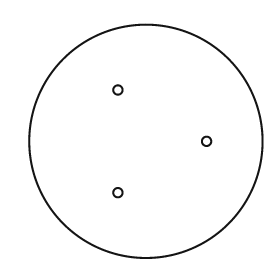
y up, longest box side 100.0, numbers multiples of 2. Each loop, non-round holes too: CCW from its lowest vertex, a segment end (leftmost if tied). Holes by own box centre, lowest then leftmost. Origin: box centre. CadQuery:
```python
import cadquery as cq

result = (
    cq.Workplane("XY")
    .moveTo(0.0, 0.0)
    .circle(50.0)
    .moveTo(-12.0, -22.0)
    .circle(2.0)
    .moveTo(26.0, 0.0)
    .circle(2.0)
    .moveTo(-12.0, 22.0)
    .circle(2.0)
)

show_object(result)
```